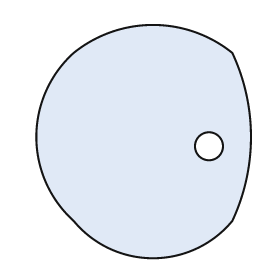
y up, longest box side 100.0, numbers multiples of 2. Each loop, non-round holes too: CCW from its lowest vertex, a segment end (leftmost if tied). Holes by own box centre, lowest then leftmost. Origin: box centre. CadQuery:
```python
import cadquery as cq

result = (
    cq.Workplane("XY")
    .moveTo(-30.0, -34.0)
    .threePointArc((4.0, -50.0), (38.0, -34.0))
    .threePointArc((46.0, 2.0), (38.0, 38.0))
    .threePointArc((4.0, 50.0), (-30.0, 38.0))
    .threePointArc((-46.0, 2.0), (-30.0, -34.0))
    .close()
    .moveTo(28.0, -2.0)
    .circle(6.0)
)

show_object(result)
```